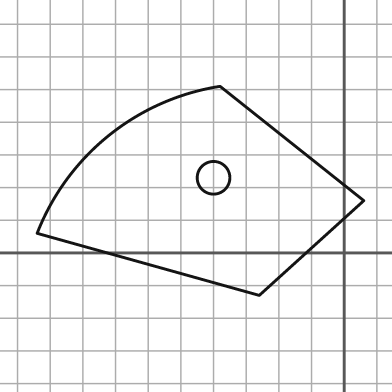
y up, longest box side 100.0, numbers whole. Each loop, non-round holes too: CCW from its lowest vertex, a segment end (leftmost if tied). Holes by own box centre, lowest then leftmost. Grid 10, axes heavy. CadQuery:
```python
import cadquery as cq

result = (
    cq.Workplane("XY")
    .moveTo(-26.0, -13.0)
    .lineTo(6.0, 16.0)
    .lineTo(-38.0, 51.0)
    .threePointArc((-72.0, 36.0), (-94.0, 6.0))
    .close()
    .moveTo(-40.0, 23.0)
    .circle(5.0)
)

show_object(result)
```